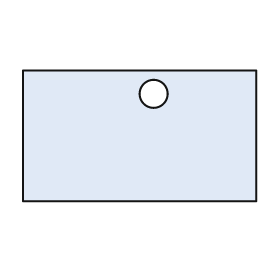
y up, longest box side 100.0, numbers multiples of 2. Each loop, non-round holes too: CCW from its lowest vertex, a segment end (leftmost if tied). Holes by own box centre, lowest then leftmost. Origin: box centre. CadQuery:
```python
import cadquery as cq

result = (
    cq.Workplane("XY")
    .moveTo(-50.0, -28.0)
    .lineTo(50.0, -28.0)
    .lineTo(50.0, 28.0)
    .lineTo(-50.0, 28.0)
    .close()
    .moveTo(6.0, 18.0)
    .circle(6.0)
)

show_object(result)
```